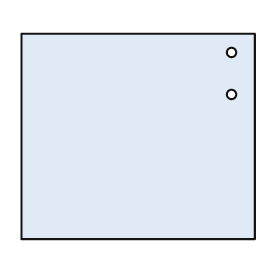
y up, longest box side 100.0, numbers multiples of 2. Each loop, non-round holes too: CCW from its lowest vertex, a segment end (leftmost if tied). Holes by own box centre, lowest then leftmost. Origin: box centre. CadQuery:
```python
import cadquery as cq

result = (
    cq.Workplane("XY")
    .moveTo(-50.0, -44.0)
    .lineTo(50.0, -44.0)
    .lineTo(50.0, 44.0)
    .lineTo(-50.0, 44.0)
    .close()
    .moveTo(40.0, 18.0)
    .circle(2.0)
    .moveTo(40.0, 36.0)
    .circle(2.0)
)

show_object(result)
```